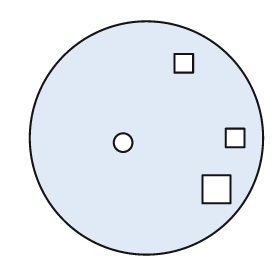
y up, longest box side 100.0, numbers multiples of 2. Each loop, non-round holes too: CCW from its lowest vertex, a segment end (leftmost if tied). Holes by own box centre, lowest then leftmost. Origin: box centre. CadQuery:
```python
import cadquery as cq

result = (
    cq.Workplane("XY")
    .moveTo(0.0, 0.0)
    .circle(50.0)
    .moveTo(24.0, -28.0)
    .lineTo(36.0, -28.0)
    .lineTo(36.0, -16.0)
    .lineTo(24.0, -16.0)
    .close()
    .moveTo(-10.0, -2.0)
    .circle(4.0)
    .moveTo(34.0, -4.0)
    .lineTo(42.0, -4.0)
    .lineTo(42.0, 4.0)
    .lineTo(34.0, 4.0)
    .close()
    .moveTo(12.0, 28.0)
    .lineTo(20.0, 28.0)
    .lineTo(20.0, 36.0)
    .lineTo(12.0, 36.0)
    .close()
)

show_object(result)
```